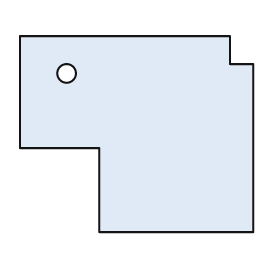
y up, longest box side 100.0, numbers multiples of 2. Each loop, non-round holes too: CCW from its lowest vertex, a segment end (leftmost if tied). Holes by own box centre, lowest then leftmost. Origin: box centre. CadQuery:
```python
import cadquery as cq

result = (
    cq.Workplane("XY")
    .moveTo(-16.0, -42.0)
    .lineTo(50.0, -42.0)
    .lineTo(50.0, 30.0)
    .lineTo(40.0, 30.0)
    .lineTo(40.0, 42.0)
    .lineTo(-50.0, 42.0)
    .lineTo(-50.0, -6.0)
    .lineTo(-16.0, -6.0)
    .close()
    .moveTo(-30.0, 26.0)
    .circle(4.0)
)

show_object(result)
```